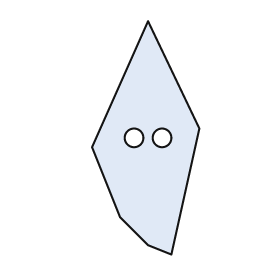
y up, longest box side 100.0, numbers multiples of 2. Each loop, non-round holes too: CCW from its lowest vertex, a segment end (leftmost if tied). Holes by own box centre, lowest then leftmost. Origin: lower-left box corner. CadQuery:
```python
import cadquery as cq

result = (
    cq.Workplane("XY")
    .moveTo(34.0, 0.0)
    .lineTo(46.0, 54.0)
    .lineTo(24.0, 100.0)
    .lineTo(0.0, 46.0)
    .lineTo(12.0, 16.0)
    .lineTo(24.0, 4.0)
    .close()
    .moveTo(18.0, 50.0)
    .circle(4.0)
    .moveTo(30.0, 50.0)
    .circle(4.0)
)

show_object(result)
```